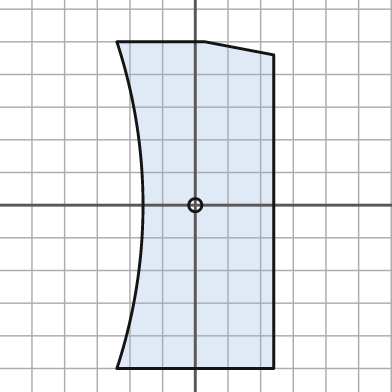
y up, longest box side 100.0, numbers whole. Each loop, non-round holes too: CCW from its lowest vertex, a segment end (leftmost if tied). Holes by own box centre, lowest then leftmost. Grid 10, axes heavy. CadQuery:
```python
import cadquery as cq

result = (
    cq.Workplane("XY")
    .moveTo(-24.0, -50.0)
    .lineTo(24.0, -50.0)
    .lineTo(24.0, 46.0)
    .lineTo(3.0, 50.0)
    .lineTo(-24.0, 50.0)
    .threePointArc((-16.0, 0.0), (-24.0, -50.0))
    .close()
    .moveTo(0.0, 0.0)
    .circle(2.0)
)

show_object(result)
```